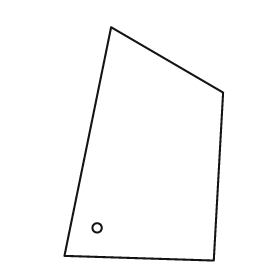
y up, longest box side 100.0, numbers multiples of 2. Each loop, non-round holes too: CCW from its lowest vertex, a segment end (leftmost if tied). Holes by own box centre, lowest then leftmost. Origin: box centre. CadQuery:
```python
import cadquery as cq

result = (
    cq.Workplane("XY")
    .moveTo(30.0, -50.0)
    .lineTo(34.0, 22.0)
    .lineTo(-14.0, 50.0)
    .lineTo(-34.0, -48.0)
    .close()
    .moveTo(-20.0, -36.0)
    .circle(2.0)
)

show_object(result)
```